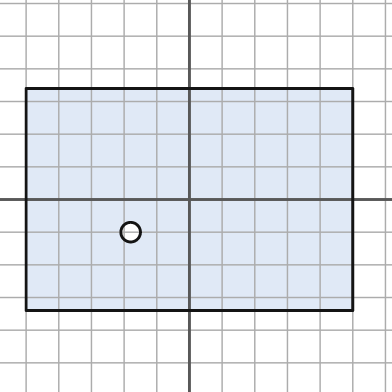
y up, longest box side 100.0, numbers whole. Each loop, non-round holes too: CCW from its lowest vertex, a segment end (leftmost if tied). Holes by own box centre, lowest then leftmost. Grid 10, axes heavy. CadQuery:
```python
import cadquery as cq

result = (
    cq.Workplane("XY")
    .moveTo(-50.0, -34.0)
    .lineTo(50.0, -34.0)
    .lineTo(50.0, 34.0)
    .lineTo(-50.0, 34.0)
    .close()
    .moveTo(-18.0, -10.0)
    .circle(3.0)
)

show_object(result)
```